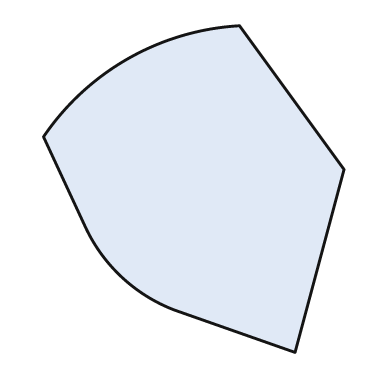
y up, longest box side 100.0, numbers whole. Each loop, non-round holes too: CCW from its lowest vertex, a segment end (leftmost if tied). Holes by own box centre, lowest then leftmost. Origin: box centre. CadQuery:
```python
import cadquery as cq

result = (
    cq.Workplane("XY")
    .moveTo(31.0, -50.0)
    .lineTo(46.0, 6.0)
    .lineTo(14.0, 50.0)
    .threePointArc((-20.0, 40.0), (-46.0, 16.0))
    .lineTo(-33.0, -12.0)
    .threePointArc((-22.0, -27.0), (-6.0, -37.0))
    .close()
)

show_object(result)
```